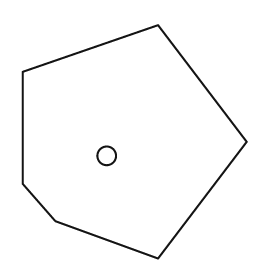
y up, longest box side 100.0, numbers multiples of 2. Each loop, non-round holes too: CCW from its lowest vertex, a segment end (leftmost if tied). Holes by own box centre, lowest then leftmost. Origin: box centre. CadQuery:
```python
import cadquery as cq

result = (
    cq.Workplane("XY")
    .moveTo(10.0, -50.0)
    .lineTo(48.0, 0.0)
    .lineTo(10.0, 50.0)
    .lineTo(-48.0, 30.0)
    .lineTo(-48.0, -18.0)
    .lineTo(-34.0, -34.0)
    .close()
    .moveTo(-12.0, -6.0)
    .circle(4.0)
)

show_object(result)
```